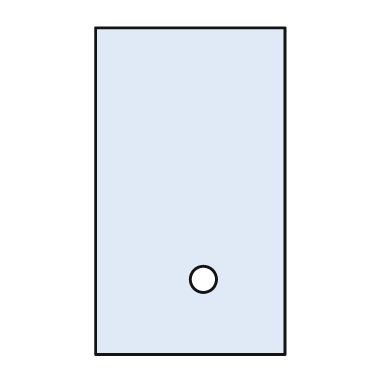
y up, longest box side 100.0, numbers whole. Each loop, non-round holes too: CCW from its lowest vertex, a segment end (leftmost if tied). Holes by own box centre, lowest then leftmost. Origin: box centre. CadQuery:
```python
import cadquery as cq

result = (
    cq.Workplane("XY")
    .moveTo(-29.0, -50.0)
    .lineTo(29.0, -50.0)
    .lineTo(29.0, 50.0)
    .lineTo(-29.0, 50.0)
    .close()
    .moveTo(4.0, -27.0)
    .circle(4.0)
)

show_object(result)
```